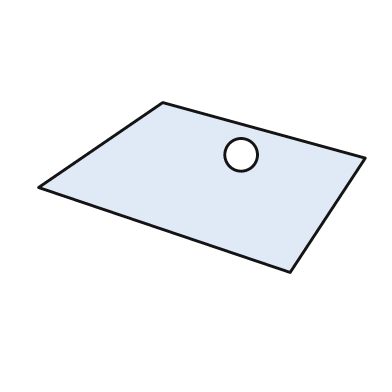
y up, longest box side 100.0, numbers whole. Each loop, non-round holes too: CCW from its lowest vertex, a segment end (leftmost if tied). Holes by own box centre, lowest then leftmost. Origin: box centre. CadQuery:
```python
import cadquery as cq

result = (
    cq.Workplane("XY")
    .moveTo(27.0, -26.0)
    .lineTo(50.0, 9.0)
    .lineTo(-12.0, 26.0)
    .lineTo(-50.0, 0.0)
    .close()
    .moveTo(12.0, 10.0)
    .circle(5.0)
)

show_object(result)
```